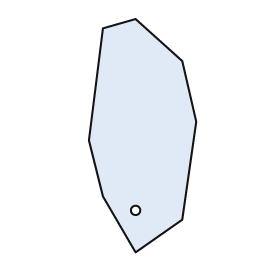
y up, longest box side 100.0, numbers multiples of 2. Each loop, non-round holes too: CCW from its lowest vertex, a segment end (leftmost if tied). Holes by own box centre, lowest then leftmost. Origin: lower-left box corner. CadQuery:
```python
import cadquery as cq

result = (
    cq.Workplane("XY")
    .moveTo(20.0, 0.0)
    .lineTo(40.0, 14.0)
    .lineTo(46.0, 56.0)
    .lineTo(40.0, 82.0)
    .lineTo(20.0, 100.0)
    .lineTo(6.0, 96.0)
    .lineTo(0.0, 48.0)
    .lineTo(6.0, 24.0)
    .close()
    .moveTo(20.0, 18.0)
    .circle(2.0)
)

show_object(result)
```